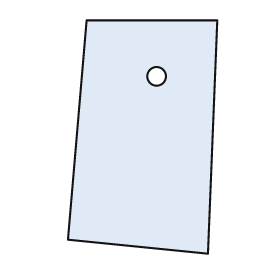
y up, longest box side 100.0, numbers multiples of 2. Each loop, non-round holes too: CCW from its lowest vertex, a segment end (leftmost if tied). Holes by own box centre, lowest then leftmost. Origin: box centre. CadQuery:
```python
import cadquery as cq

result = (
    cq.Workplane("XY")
    .moveTo(28.0, -50.0)
    .lineTo(32.0, 50.0)
    .lineTo(-24.0, 50.0)
    .lineTo(-32.0, -44.0)
    .close()
    .moveTo(6.0, 26.0)
    .circle(4.0)
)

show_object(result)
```